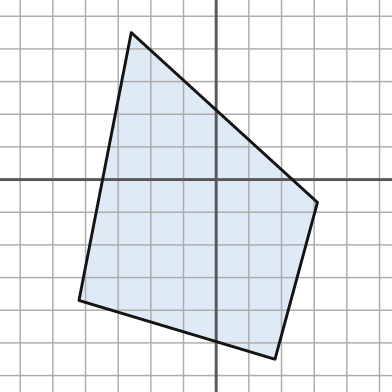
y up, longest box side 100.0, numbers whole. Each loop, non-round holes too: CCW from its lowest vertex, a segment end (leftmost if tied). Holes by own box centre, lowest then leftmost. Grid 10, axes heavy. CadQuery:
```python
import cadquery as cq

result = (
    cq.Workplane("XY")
    .moveTo(18.0, -55.0)
    .lineTo(31.0, -7.0)
    .lineTo(-26.0, 45.0)
    .lineTo(-42.0, -37.0)
    .close()
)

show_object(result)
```